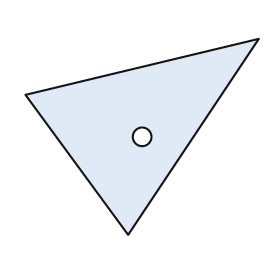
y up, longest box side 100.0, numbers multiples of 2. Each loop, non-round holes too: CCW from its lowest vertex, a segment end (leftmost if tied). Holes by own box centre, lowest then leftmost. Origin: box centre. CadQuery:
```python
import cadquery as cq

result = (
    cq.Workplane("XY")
    .moveTo(-6.0, -42.0)
    .lineTo(50.0, 42.0)
    .lineTo(-50.0, 18.0)
    .close()
    .moveTo(0.0, 0.0)
    .circle(4.0)
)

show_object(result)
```